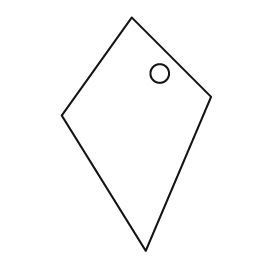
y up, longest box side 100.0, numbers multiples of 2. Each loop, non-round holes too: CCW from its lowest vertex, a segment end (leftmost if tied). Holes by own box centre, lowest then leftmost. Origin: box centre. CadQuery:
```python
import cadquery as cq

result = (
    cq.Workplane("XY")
    .moveTo(4.0, -50.0)
    .lineTo(32.0, 16.0)
    .lineTo(-2.0, 50.0)
    .lineTo(-32.0, 8.0)
    .close()
    .moveTo(10.0, 26.0)
    .circle(4.0)
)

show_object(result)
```